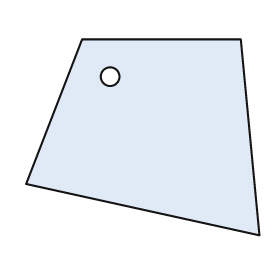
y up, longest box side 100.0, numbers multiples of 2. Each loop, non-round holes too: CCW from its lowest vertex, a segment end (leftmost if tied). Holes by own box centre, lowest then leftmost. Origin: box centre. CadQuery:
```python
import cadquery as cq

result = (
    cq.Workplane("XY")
    .moveTo(50.0, -42.0)
    .lineTo(42.0, 42.0)
    .lineTo(-26.0, 42.0)
    .lineTo(-50.0, -20.0)
    .close()
    .moveTo(-14.0, 26.0)
    .circle(4.0)
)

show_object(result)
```